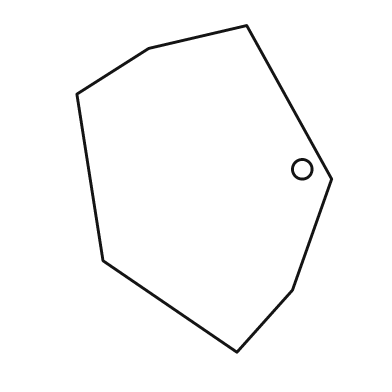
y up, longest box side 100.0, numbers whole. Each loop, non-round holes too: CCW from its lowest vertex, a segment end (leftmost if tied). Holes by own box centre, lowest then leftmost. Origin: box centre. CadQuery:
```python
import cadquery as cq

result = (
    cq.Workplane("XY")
    .moveTo(10.0, -50.0)
    .lineTo(27.0, -31.0)
    .lineTo(39.0, 3.0)
    .lineTo(13.0, 50.0)
    .lineTo(-17.0, 43.0)
    .lineTo(-39.0, 29.0)
    .lineTo(-31.0, -22.0)
    .close()
    .moveTo(30.0, 6.0)
    .circle(3.0)
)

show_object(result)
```